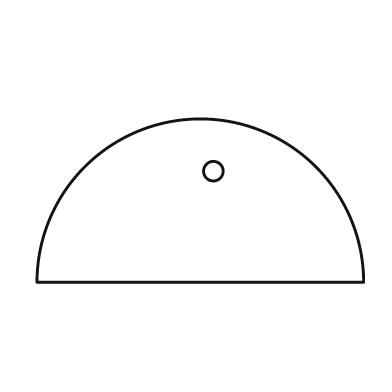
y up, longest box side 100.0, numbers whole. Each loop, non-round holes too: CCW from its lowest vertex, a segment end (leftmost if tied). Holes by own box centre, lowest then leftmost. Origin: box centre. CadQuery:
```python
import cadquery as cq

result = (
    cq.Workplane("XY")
    .moveTo(-50.0, -25.0)
    .lineTo(50.0, -25.0)
    .threePointArc((0.0, 25.0), (-50.0, -25.0))
    .close()
    .moveTo(4.0, 9.0)
    .circle(3.0)
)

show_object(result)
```